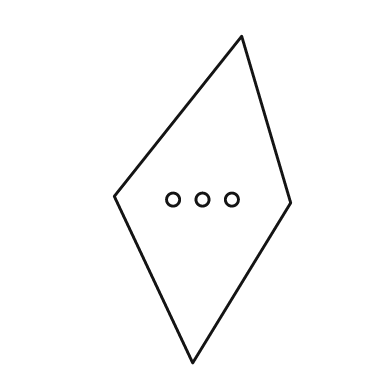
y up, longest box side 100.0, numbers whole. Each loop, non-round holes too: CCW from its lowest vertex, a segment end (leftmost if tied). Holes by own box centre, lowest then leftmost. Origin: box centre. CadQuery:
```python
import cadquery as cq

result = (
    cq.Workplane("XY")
    .moveTo(-3.0, -50.0)
    .lineTo(27.0, -1.0)
    .lineTo(12.0, 50.0)
    .lineTo(-27.0, 1.0)
    .close()
    .moveTo(-9.0, 0.0)
    .circle(2.0)
    .moveTo(0.0, 0.0)
    .circle(2.0)
    .moveTo(9.0, 0.0)
    .circle(2.0)
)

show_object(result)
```